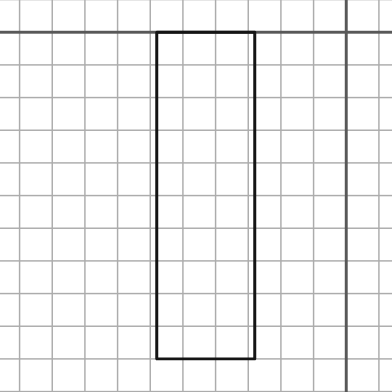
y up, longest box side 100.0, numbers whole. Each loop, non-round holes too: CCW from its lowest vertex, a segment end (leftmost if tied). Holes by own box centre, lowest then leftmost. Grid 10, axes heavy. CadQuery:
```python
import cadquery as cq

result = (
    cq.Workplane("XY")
    .moveTo(-58.0, -100.0)
    .lineTo(-28.0, -100.0)
    .lineTo(-28.0, 0.0)
    .lineTo(-58.0, 0.0)
    .close()
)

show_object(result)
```